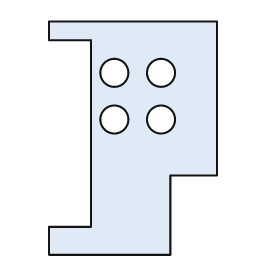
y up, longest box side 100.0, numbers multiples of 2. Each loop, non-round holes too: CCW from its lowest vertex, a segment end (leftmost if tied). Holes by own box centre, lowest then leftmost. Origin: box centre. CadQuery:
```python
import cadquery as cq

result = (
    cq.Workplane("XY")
    .moveTo(-36.0, -50.0)
    .lineTo(16.0, -50.0)
    .lineTo(16.0, -16.0)
    .lineTo(36.0, -16.0)
    .lineTo(36.0, 50.0)
    .lineTo(-36.0, 50.0)
    .lineTo(-36.0, 42.0)
    .lineTo(-18.0, 42.0)
    .lineTo(-18.0, -38.0)
    .lineTo(-36.0, -38.0)
    .close()
    .moveTo(-8.0, 8.0)
    .circle(6.0)
    .moveTo(12.0, 8.0)
    .circle(6.0)
    .moveTo(-8.0, 28.0)
    .circle(6.0)
    .moveTo(12.0, 28.0)
    .circle(6.0)
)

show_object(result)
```